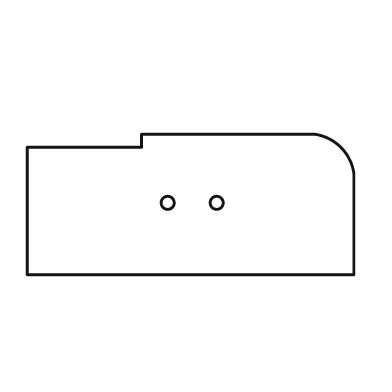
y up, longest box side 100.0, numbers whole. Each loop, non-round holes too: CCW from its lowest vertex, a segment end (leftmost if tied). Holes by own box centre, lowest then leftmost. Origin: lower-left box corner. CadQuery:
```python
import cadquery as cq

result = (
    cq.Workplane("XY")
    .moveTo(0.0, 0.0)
    .lineTo(100.0, 0.0)
    .lineTo(100.0, 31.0)
    .threePointArc((96.0, 39.0), (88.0, 43.0))
    .lineTo(35.0, 43.0)
    .lineTo(35.0, 39.0)
    .lineTo(0.0, 39.0)
    .close()
    .moveTo(43.0, 22.0)
    .circle(2.0)
    .moveTo(58.0, 22.0)
    .circle(2.0)
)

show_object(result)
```